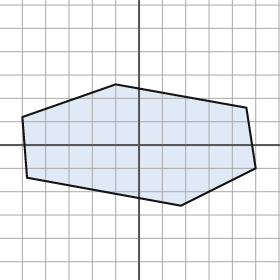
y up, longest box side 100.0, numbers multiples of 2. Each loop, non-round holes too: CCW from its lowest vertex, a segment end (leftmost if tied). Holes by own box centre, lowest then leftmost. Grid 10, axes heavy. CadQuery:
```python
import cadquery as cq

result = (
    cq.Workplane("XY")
    .moveTo(18.0, -26.0)
    .lineTo(50.0, -10.0)
    .lineTo(46.0, 16.0)
    .lineTo(-10.0, 26.0)
    .lineTo(-50.0, 12.0)
    .lineTo(-48.0, -14.0)
    .close()
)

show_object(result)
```